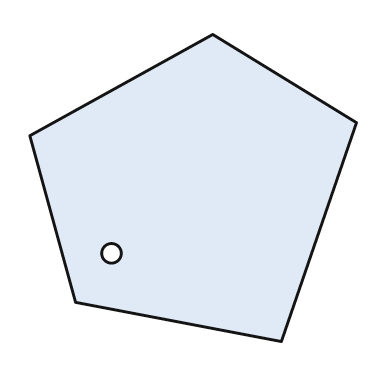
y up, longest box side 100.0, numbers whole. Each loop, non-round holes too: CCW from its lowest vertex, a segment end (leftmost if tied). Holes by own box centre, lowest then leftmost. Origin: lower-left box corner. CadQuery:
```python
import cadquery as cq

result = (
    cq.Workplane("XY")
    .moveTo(77.0, 0.0)
    .lineTo(100.0, 67.0)
    .lineTo(56.0, 94.0)
    .lineTo(0.0, 63.0)
    .lineTo(14.0, 12.0)
    .close()
    .moveTo(25.0, 27.0)
    .circle(3.0)
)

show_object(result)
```